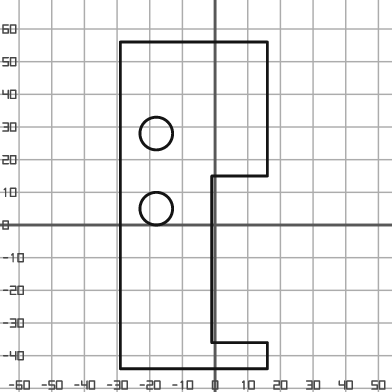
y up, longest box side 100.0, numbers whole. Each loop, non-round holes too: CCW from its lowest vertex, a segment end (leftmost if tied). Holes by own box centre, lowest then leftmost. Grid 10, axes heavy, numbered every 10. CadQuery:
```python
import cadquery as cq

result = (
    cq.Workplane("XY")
    .moveTo(-29.0, -44.0)
    .lineTo(16.0, -44.0)
    .lineTo(16.0, -36.0)
    .lineTo(-1.0, -36.0)
    .lineTo(-1.0, 15.0)
    .lineTo(16.0, 15.0)
    .lineTo(16.0, 56.0)
    .lineTo(-29.0, 56.0)
    .close()
    .moveTo(-18.0, 5.0)
    .circle(5.0)
    .moveTo(-18.0, 28.0)
    .circle(5.0)
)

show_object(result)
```